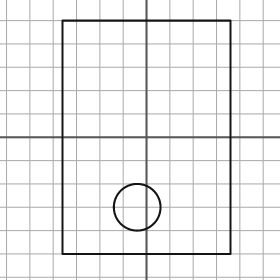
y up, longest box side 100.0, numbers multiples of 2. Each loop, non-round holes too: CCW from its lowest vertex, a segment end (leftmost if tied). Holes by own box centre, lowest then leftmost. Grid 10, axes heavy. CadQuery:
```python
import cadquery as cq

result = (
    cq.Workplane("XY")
    .moveTo(-36.0, -50.0)
    .lineTo(36.0, -50.0)
    .lineTo(36.0, 50.0)
    .lineTo(-36.0, 50.0)
    .close()
    .moveTo(-4.0, -30.0)
    .circle(10.0)
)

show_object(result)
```